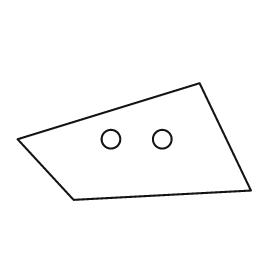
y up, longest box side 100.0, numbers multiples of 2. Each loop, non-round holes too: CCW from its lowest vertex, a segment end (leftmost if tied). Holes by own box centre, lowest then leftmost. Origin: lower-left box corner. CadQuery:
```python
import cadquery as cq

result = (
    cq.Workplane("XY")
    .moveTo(24.0, 0.0)
    .lineTo(100.0, 4.0)
    .lineTo(78.0, 50.0)
    .lineTo(0.0, 26.0)
    .close()
    .moveTo(40.0, 26.0)
    .circle(4.0)
    .moveTo(62.0, 26.0)
    .circle(4.0)
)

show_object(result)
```